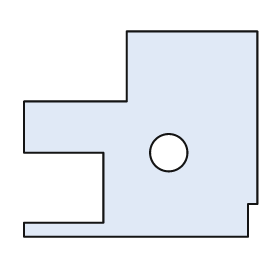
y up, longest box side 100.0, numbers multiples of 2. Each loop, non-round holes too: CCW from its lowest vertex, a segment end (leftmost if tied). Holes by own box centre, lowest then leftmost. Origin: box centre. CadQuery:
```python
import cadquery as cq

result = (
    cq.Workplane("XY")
    .moveTo(-50.0, -44.0)
    .lineTo(46.0, -44.0)
    .lineTo(46.0, -30.0)
    .lineTo(50.0, -30.0)
    .lineTo(50.0, 44.0)
    .lineTo(-6.0, 44.0)
    .lineTo(-6.0, 14.0)
    .lineTo(-50.0, 14.0)
    .lineTo(-50.0, -8.0)
    .lineTo(-16.0, -8.0)
    .lineTo(-16.0, -38.0)
    .lineTo(-50.0, -38.0)
    .close()
    .moveTo(12.0, -8.0)
    .circle(8.0)
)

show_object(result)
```